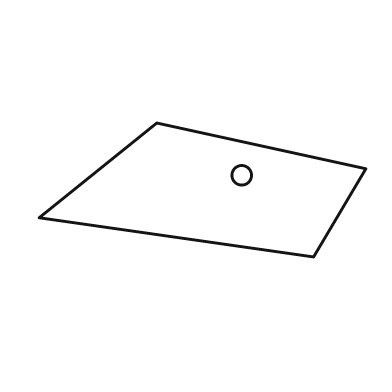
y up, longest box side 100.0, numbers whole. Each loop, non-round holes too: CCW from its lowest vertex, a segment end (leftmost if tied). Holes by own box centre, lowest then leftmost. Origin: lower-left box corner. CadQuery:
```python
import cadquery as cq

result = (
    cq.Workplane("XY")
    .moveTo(84.0, 0.0)
    .lineTo(100.0, 27.0)
    .lineTo(36.0, 41.0)
    .lineTo(0.0, 12.0)
    .close()
    .moveTo(62.0, 25.0)
    .circle(3.0)
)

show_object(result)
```